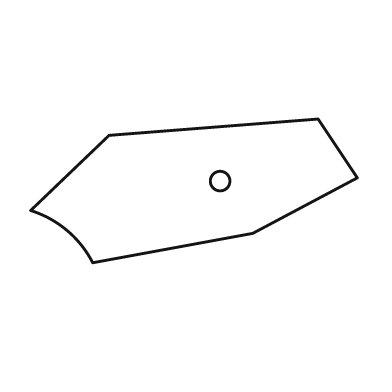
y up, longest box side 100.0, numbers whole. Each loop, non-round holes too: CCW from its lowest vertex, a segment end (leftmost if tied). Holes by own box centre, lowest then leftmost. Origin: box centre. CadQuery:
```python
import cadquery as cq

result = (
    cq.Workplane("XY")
    .moveTo(-31.0, -22.0)
    .lineTo(18.0, -13.0)
    .lineTo(50.0, 4.0)
    .lineTo(38.0, 22.0)
    .lineTo(-26.0, 17.0)
    .lineTo(-50.0, -6.0)
    .threePointArc((-39.0, -12.0), (-31.0, -22.0))
    .close()
    .moveTo(8.0, 3.0)
    .circle(3.0)
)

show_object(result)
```